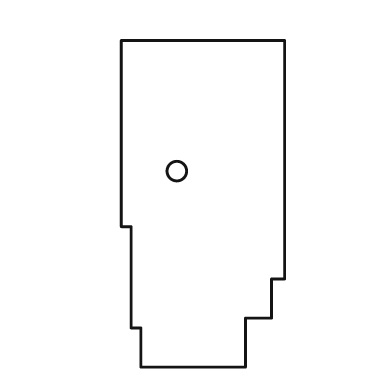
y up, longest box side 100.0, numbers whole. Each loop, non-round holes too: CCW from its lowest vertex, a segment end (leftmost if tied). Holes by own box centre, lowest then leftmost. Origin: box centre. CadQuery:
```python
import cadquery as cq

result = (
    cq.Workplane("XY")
    .moveTo(-19.0, -50.0)
    .lineTo(13.0, -50.0)
    .lineTo(13.0, -35.0)
    .lineTo(21.0, -35.0)
    .lineTo(21.0, -23.0)
    .lineTo(25.0, -23.0)
    .lineTo(25.0, 50.0)
    .lineTo(-25.0, 50.0)
    .lineTo(-25.0, -7.0)
    .lineTo(-22.0, -7.0)
    .lineTo(-22.0, -38.0)
    .lineTo(-19.0, -38.0)
    .close()
    .moveTo(-8.0, 10.0)
    .circle(3.0)
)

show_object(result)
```